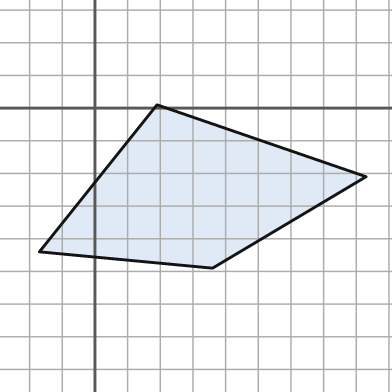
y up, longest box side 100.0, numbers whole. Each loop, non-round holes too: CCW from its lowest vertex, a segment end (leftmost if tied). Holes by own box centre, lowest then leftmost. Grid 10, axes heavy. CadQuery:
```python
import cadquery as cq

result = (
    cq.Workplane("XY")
    .moveTo(36.0, -49.0)
    .lineTo(83.0, -21.0)
    .lineTo(19.0, 1.0)
    .lineTo(-17.0, -44.0)
    .close()
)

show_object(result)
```